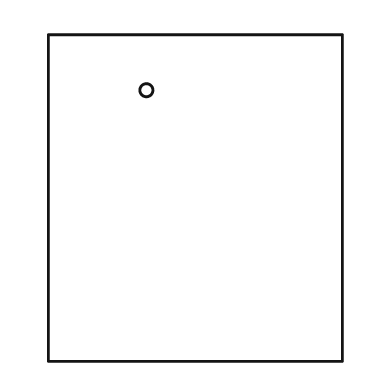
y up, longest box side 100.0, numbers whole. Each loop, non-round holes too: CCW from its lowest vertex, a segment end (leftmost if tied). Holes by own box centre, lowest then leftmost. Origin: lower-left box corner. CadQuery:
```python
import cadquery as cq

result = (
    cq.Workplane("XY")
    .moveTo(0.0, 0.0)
    .lineTo(90.0, 0.0)
    .lineTo(90.0, 100.0)
    .lineTo(0.0, 100.0)
    .close()
    .moveTo(30.0, 83.0)
    .circle(2.0)
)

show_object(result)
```